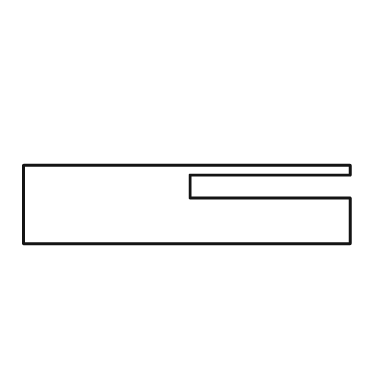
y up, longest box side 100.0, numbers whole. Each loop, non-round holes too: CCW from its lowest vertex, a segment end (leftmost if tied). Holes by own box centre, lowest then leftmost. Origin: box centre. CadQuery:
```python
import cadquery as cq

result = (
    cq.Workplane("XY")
    .moveTo(-50.0, -12.0)
    .lineTo(50.0, -12.0)
    .lineTo(50.0, 2.0)
    .lineTo(1.0, 2.0)
    .lineTo(1.0, 9.0)
    .lineTo(50.0, 9.0)
    .lineTo(50.0, 12.0)
    .lineTo(-50.0, 12.0)
    .close()
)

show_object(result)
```